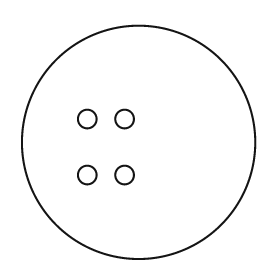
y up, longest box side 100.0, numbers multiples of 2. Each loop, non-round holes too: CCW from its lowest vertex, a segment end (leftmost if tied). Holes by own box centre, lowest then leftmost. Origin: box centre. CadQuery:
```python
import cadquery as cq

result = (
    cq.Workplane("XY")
    .moveTo(0.0, 0.0)
    .circle(50.0)
    .moveTo(-22.0, -14.0)
    .circle(4.0)
    .moveTo(-6.0, -14.0)
    .circle(4.0)
    .moveTo(-22.0, 10.0)
    .circle(4.0)
    .moveTo(-6.0, 10.0)
    .circle(4.0)
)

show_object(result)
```